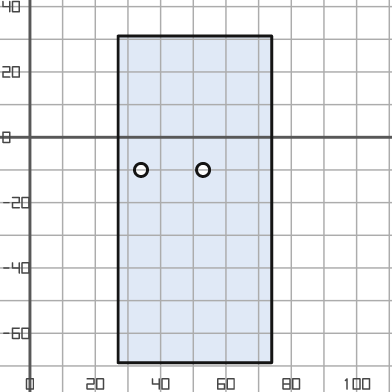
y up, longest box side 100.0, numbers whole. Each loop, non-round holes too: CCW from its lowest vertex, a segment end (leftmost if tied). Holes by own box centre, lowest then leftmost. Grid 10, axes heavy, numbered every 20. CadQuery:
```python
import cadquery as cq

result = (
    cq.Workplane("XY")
    .moveTo(27.0, -69.0)
    .lineTo(74.0, -69.0)
    .lineTo(74.0, 31.0)
    .lineTo(27.0, 31.0)
    .close()
    .moveTo(34.0, -10.0)
    .circle(2.0)
    .moveTo(53.0, -10.0)
    .circle(2.0)
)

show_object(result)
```